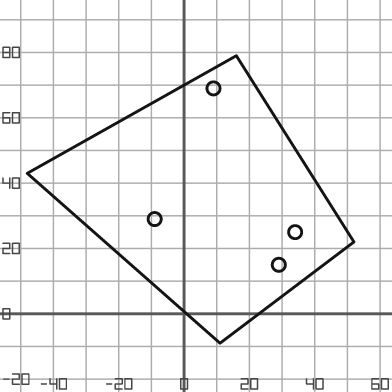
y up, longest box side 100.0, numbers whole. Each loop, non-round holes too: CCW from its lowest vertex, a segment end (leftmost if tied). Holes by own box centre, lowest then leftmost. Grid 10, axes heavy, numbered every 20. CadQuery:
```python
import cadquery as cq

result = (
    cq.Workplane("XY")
    .moveTo(11.0, -9.0)
    .lineTo(52.0, 22.0)
    .lineTo(16.0, 79.0)
    .lineTo(-48.0, 43.0)
    .close()
    .moveTo(29.0, 15.0)
    .circle(2.0)
    .moveTo(34.0, 25.0)
    .circle(2.0)
    .moveTo(-9.0, 29.0)
    .circle(2.0)
    .moveTo(9.0, 69.0)
    .circle(2.0)
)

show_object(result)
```